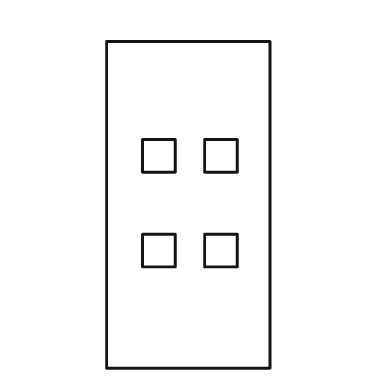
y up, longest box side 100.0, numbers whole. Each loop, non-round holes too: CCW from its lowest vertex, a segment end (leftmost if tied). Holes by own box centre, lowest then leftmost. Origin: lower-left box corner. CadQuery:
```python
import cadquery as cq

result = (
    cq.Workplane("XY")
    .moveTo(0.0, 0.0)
    .lineTo(50.0, 0.0)
    .lineTo(50.0, 100.0)
    .lineTo(0.0, 100.0)
    .close()
    .moveTo(11.0, 31.0)
    .lineTo(21.0, 31.0)
    .lineTo(21.0, 41.0)
    .lineTo(11.0, 41.0)
    .close()
    .moveTo(30.0, 31.0)
    .lineTo(40.0, 31.0)
    .lineTo(40.0, 41.0)
    .lineTo(30.0, 41.0)
    .close()
    .moveTo(11.0, 60.0)
    .lineTo(21.0, 60.0)
    .lineTo(21.0, 70.0)
    .lineTo(11.0, 70.0)
    .close()
    .moveTo(30.0, 60.0)
    .lineTo(40.0, 60.0)
    .lineTo(40.0, 70.0)
    .lineTo(30.0, 70.0)
    .close()
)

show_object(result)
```